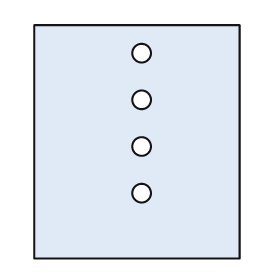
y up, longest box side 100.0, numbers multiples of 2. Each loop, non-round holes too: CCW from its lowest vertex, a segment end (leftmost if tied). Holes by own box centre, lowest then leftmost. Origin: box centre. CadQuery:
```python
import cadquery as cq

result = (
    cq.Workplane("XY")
    .moveTo(-44.0, -50.0)
    .lineTo(44.0, -50.0)
    .lineTo(44.0, 50.0)
    .lineTo(-44.0, 50.0)
    .close()
    .moveTo(2.0, -22.0)
    .circle(4.0)
    .moveTo(2.0, -2.0)
    .circle(4.0)
    .moveTo(2.0, 18.0)
    .circle(4.0)
    .moveTo(2.0, 38.0)
    .circle(4.0)
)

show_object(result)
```